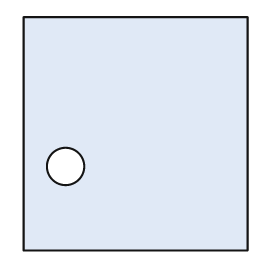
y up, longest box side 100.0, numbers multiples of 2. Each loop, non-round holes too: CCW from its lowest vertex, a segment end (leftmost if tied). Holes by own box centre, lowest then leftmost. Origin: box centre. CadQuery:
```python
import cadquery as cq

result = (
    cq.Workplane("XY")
    .moveTo(-48.0, -50.0)
    .lineTo(48.0, -50.0)
    .lineTo(48.0, 50.0)
    .lineTo(-48.0, 50.0)
    .close()
    .moveTo(-30.0, -14.0)
    .circle(8.0)
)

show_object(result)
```